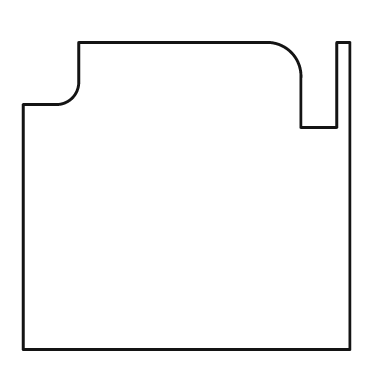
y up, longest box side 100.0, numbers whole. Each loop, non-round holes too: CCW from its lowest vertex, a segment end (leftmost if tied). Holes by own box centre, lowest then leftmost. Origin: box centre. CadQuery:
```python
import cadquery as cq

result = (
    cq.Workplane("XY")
    .moveTo(-50.0, -47.0)
    .lineTo(50.0, -47.0)
    .lineTo(50.0, 47.0)
    .lineTo(46.0, 47.0)
    .lineTo(46.0, 21.0)
    .lineTo(35.0, 21.0)
    .lineTo(35.0, 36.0)
    .threePointArc((32.0, 44.0), (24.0, 47.0))
    .lineTo(-33.0, 47.0)
    .lineTo(-33.0, 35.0)
    .threePointArc((-35.0, 30.0), (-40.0, 28.0))
    .lineTo(-50.0, 28.0)
    .close()
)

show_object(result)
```